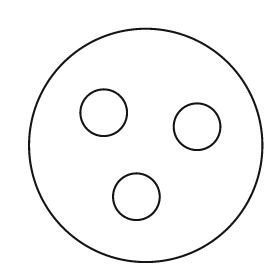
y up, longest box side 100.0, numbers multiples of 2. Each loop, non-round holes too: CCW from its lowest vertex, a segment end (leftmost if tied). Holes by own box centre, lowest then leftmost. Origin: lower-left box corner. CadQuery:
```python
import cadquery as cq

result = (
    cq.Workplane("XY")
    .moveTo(50.0, 50.0)
    .circle(50.0)
    .moveTo(46.0, 28.0)
    .circle(10.0)
    .moveTo(72.0, 58.0)
    .circle(10.0)
    .moveTo(32.0, 64.0)
    .circle(10.0)
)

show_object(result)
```